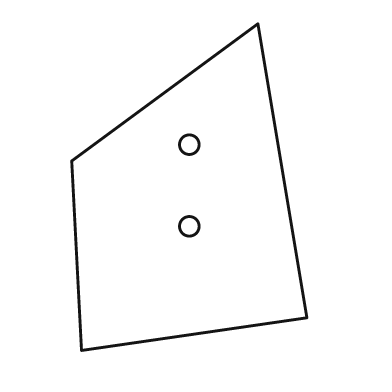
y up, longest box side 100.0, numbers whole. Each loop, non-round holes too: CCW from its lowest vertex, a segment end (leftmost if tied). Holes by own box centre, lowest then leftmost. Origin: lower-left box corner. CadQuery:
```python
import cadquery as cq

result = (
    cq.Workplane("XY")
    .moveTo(3.0, 0.0)
    .lineTo(72.0, 10.0)
    .lineTo(57.0, 100.0)
    .lineTo(0.0, 58.0)
    .close()
    .moveTo(36.0, 38.0)
    .circle(3.0)
    .moveTo(36.0, 63.0)
    .circle(3.0)
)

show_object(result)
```